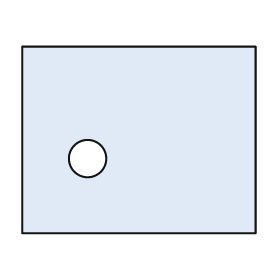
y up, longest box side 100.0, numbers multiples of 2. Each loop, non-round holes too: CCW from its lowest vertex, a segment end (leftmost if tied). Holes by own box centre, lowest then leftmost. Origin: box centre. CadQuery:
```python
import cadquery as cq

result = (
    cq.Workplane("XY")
    .moveTo(-50.0, -40.0)
    .lineTo(50.0, -40.0)
    .lineTo(50.0, 40.0)
    .lineTo(-50.0, 40.0)
    .close()
    .moveTo(-22.0, -8.0)
    .circle(8.0)
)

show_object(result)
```